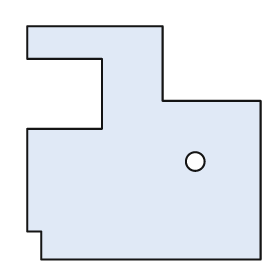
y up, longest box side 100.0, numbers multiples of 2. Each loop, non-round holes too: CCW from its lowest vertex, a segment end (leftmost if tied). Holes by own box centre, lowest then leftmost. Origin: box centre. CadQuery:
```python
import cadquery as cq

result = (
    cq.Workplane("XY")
    .moveTo(-44.0, -50.0)
    .lineTo(50.0, -50.0)
    .lineTo(50.0, 18.0)
    .lineTo(8.0, 18.0)
    .lineTo(8.0, 50.0)
    .lineTo(-50.0, 50.0)
    .lineTo(-50.0, 36.0)
    .lineTo(-18.0, 36.0)
    .lineTo(-18.0, 6.0)
    .lineTo(-50.0, 6.0)
    .lineTo(-50.0, -38.0)
    .lineTo(-44.0, -38.0)
    .close()
    .moveTo(22.0, -8.0)
    .circle(4.0)
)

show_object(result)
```